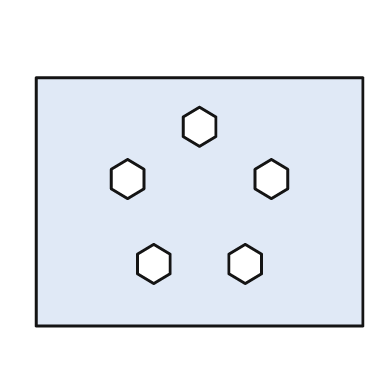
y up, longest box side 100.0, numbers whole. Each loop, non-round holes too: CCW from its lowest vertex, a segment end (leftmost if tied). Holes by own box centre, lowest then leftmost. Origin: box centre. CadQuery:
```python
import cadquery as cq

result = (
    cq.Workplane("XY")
    .moveTo(-50.0, -38.0)
    .lineTo(50.0, -38.0)
    .lineTo(50.0, 38.0)
    .lineTo(-50.0, 38.0)
    .close()
    .moveTo(-14.0, -25.0)
    .lineTo(-9.0, -22.0)
    .lineTo(-9.0, -16.0)
    .lineTo(-14.0, -13.0)
    .lineTo(-19.0, -16.0)
    .lineTo(-19.0, -22.0)
    .close()
    .moveTo(14.0, -25.0)
    .lineTo(19.0, -22.0)
    .lineTo(19.0, -16.0)
    .lineTo(14.0, -13.0)
    .lineTo(9.0, -16.0)
    .lineTo(9.0, -22.0)
    .close()
    .moveTo(-22.0, 1.0)
    .lineTo(-17.0, 4.0)
    .lineTo(-17.0, 10.0)
    .lineTo(-22.0, 13.0)
    .lineTo(-27.0, 10.0)
    .lineTo(-27.0, 4.0)
    .close()
    .moveTo(22.0, 1.0)
    .lineTo(27.0, 4.0)
    .lineTo(27.0, 10.0)
    .lineTo(22.0, 13.0)
    .lineTo(17.0, 10.0)
    .lineTo(17.0, 4.0)
    .close()
    .moveTo(0.0, 17.0)
    .lineTo(5.0, 20.0)
    .lineTo(5.0, 26.0)
    .lineTo(0.0, 29.0)
    .lineTo(-5.0, 26.0)
    .lineTo(-5.0, 20.0)
    .close()
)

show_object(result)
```